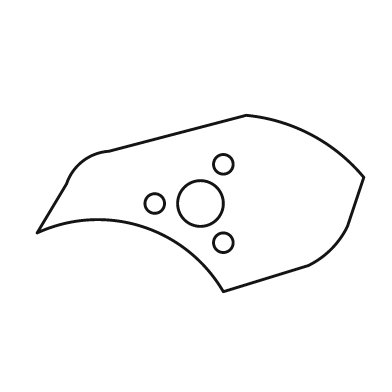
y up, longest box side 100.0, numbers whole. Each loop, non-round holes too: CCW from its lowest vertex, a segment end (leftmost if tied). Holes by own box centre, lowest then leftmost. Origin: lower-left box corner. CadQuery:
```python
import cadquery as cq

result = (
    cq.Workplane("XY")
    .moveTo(57.0, 0.0)
    .lineTo(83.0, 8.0)
    .threePointArc((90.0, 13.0), (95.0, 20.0))
    .lineTo(100.0, 35.0)
    .threePointArc((84.0, 48.0), (64.0, 54.0))
    .lineTo(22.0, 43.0)
    .threePointArc((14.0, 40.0), (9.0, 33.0))
    .lineTo(0.0, 18.0)
    .threePointArc((32.0, 20.0), (57.0, 0.0))
    .close()
    .moveTo(57.0, 15.0)
    .circle(3.0)
    .moveTo(36.0, 27.0)
    .circle(3.0)
    .moveTo(50.0, 27.0)
    .circle(7.0)
    .moveTo(57.0, 39.0)
    .circle(3.0)
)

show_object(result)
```